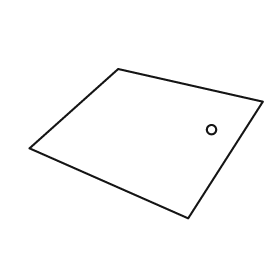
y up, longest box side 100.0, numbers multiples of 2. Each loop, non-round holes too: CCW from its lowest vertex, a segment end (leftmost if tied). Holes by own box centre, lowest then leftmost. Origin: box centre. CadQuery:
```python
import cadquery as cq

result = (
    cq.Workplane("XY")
    .moveTo(18.0, -32.0)
    .lineTo(50.0, 18.0)
    .lineTo(-12.0, 32.0)
    .lineTo(-50.0, -2.0)
    .close()
    .moveTo(28.0, 6.0)
    .circle(2.0)
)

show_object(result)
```